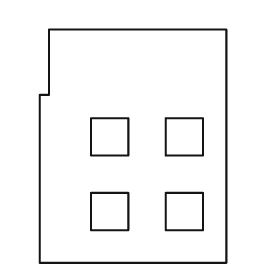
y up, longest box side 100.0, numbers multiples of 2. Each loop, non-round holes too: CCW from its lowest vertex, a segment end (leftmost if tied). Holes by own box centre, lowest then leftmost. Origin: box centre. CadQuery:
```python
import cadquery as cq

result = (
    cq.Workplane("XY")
    .moveTo(-40.0, -50.0)
    .lineTo(40.0, -50.0)
    .lineTo(40.0, 50.0)
    .lineTo(-36.0, 50.0)
    .lineTo(-36.0, 22.0)
    .lineTo(-40.0, 22.0)
    .close()
    .moveTo(-18.0, -36.0)
    .lineTo(-2.0, -36.0)
    .lineTo(-2.0, -20.0)
    .lineTo(-18.0, -20.0)
    .close()
    .moveTo(14.0, -36.0)
    .lineTo(30.0, -36.0)
    .lineTo(30.0, -20.0)
    .lineTo(14.0, -20.0)
    .close()
    .moveTo(-18.0, -4.0)
    .lineTo(-2.0, -4.0)
    .lineTo(-2.0, 12.0)
    .lineTo(-18.0, 12.0)
    .close()
    .moveTo(14.0, -4.0)
    .lineTo(30.0, -4.0)
    .lineTo(30.0, 12.0)
    .lineTo(14.0, 12.0)
    .close()
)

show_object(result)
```